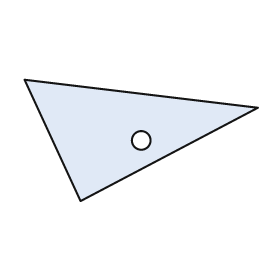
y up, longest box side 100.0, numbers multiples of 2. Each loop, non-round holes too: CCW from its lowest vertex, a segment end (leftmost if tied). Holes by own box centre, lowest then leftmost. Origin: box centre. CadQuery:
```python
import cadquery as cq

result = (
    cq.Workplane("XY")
    .moveTo(-26.0, -26.0)
    .lineTo(50.0, 14.0)
    .lineTo(-50.0, 26.0)
    .close()
    .moveTo(0.0, 0.0)
    .circle(4.0)
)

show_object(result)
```